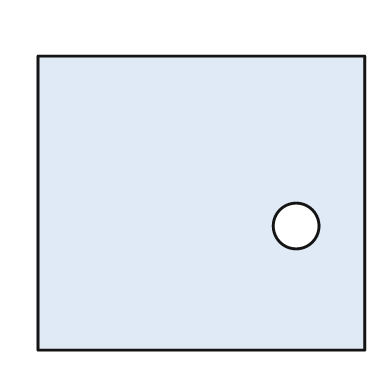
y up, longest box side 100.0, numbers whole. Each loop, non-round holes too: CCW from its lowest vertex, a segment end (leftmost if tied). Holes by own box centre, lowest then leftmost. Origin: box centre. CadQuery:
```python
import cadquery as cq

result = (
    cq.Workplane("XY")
    .moveTo(-50.0, -45.0)
    .lineTo(50.0, -45.0)
    .lineTo(50.0, 45.0)
    .lineTo(-50.0, 45.0)
    .close()
    .moveTo(29.0, -7.0)
    .circle(7.0)
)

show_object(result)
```